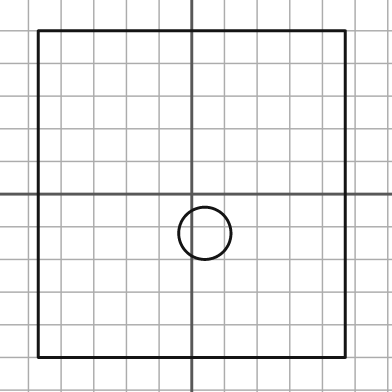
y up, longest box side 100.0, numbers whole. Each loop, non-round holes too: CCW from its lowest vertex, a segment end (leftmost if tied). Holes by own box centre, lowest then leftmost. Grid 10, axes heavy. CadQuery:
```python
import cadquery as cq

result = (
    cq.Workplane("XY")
    .moveTo(-47.0, -50.0)
    .lineTo(47.0, -50.0)
    .lineTo(47.0, 50.0)
    .lineTo(-47.0, 50.0)
    .close()
    .moveTo(4.0, -12.0)
    .circle(8.0)
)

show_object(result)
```